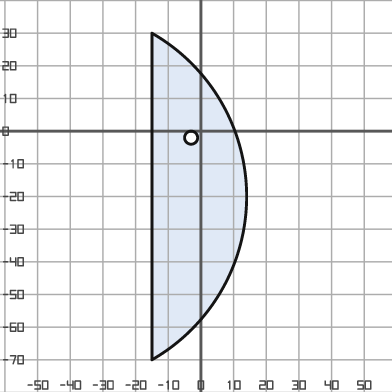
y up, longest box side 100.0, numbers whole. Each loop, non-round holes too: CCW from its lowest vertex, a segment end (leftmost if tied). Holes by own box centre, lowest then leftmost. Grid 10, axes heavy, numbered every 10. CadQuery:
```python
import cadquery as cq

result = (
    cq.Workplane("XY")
    .moveTo(-15.0, -70.0)
    .threePointArc((14.0, -20.0), (-15.0, 30.0))
    .close()
    .moveTo(-3.0, -2.0)
    .circle(2.0)
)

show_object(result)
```